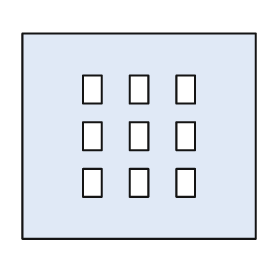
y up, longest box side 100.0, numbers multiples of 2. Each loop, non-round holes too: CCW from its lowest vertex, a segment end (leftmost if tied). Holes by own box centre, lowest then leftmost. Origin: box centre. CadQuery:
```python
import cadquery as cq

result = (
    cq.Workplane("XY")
    .moveTo(-50.0, -44.0)
    .lineTo(50.0, -44.0)
    .lineTo(50.0, 44.0)
    .lineTo(-50.0, 44.0)
    .close()
    .moveTo(-24.0, -26.0)
    .lineTo(-16.0, -26.0)
    .lineTo(-16.0, -14.0)
    .lineTo(-24.0, -14.0)
    .close()
    .moveTo(-4.0, -26.0)
    .lineTo(4.0, -26.0)
    .lineTo(4.0, -14.0)
    .lineTo(-4.0, -14.0)
    .close()
    .moveTo(16.0, -26.0)
    .lineTo(24.0, -26.0)
    .lineTo(24.0, -14.0)
    .lineTo(16.0, -14.0)
    .close()
    .moveTo(-24.0, -6.0)
    .lineTo(-16.0, -6.0)
    .lineTo(-16.0, 6.0)
    .lineTo(-24.0, 6.0)
    .close()
    .moveTo(-4.0, -6.0)
    .lineTo(4.0, -6.0)
    .lineTo(4.0, 6.0)
    .lineTo(-4.0, 6.0)
    .close()
    .moveTo(16.0, -6.0)
    .lineTo(24.0, -6.0)
    .lineTo(24.0, 6.0)
    .lineTo(16.0, 6.0)
    .close()
    .moveTo(-24.0, 14.0)
    .lineTo(-16.0, 14.0)
    .lineTo(-16.0, 26.0)
    .lineTo(-24.0, 26.0)
    .close()
    .moveTo(-4.0, 14.0)
    .lineTo(4.0, 14.0)
    .lineTo(4.0, 26.0)
    .lineTo(-4.0, 26.0)
    .close()
    .moveTo(16.0, 14.0)
    .lineTo(24.0, 14.0)
    .lineTo(24.0, 26.0)
    .lineTo(16.0, 26.0)
    .close()
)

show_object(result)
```